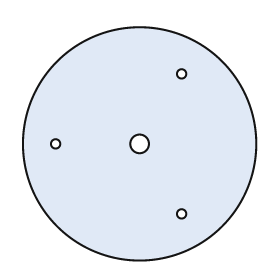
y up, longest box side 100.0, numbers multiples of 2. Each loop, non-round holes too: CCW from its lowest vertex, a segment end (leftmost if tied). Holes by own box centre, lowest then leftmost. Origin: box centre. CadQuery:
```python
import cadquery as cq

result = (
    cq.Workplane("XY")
    .moveTo(0.0, 0.0)
    .circle(50.0)
    .moveTo(18.0, -30.0)
    .circle(2.0)
    .moveTo(-36.0, 0.0)
    .circle(2.0)
    .moveTo(0.0, 0.0)
    .circle(4.0)
    .moveTo(18.0, 30.0)
    .circle(2.0)
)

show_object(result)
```